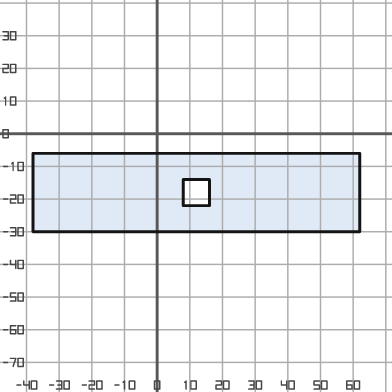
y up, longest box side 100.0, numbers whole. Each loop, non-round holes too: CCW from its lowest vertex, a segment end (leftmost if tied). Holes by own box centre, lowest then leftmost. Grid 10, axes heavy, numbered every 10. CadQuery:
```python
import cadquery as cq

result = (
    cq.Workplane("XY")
    .moveTo(-38.0, -30.0)
    .lineTo(62.0, -30.0)
    .lineTo(62.0, -6.0)
    .lineTo(-38.0, -6.0)
    .close()
    .moveTo(8.0, -22.0)
    .lineTo(16.0, -22.0)
    .lineTo(16.0, -14.0)
    .lineTo(8.0, -14.0)
    .close()
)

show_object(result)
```